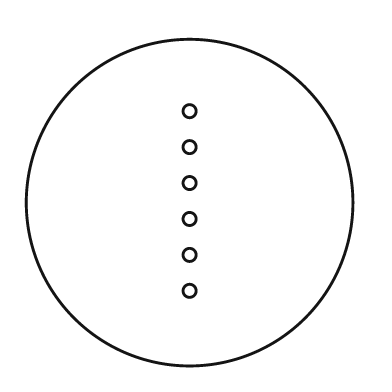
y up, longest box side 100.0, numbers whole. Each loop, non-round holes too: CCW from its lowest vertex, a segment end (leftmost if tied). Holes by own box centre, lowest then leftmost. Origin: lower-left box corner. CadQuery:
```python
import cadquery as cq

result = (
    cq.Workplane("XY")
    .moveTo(50.0, 50.0)
    .circle(50.0)
    .moveTo(50.0, 23.0)
    .circle(2.0)
    .moveTo(50.0, 34.0)
    .circle(2.0)
    .moveTo(50.0, 45.0)
    .circle(2.0)
    .moveTo(50.0, 56.0)
    .circle(2.0)
    .moveTo(50.0, 67.0)
    .circle(2.0)
    .moveTo(50.0, 78.0)
    .circle(2.0)
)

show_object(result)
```